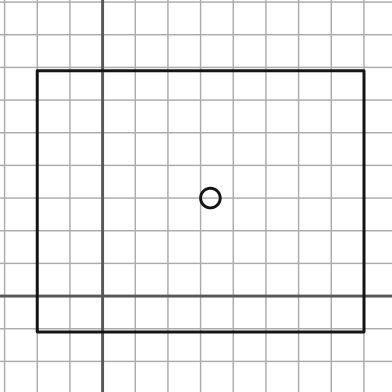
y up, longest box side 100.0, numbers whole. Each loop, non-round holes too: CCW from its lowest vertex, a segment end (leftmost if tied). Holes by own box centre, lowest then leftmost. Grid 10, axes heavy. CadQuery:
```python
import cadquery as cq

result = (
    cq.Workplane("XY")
    .moveTo(-20.0, -11.0)
    .lineTo(80.0, -11.0)
    .lineTo(80.0, 69.0)
    .lineTo(-20.0, 69.0)
    .close()
    .moveTo(33.0, 30.0)
    .circle(3.0)
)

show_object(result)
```